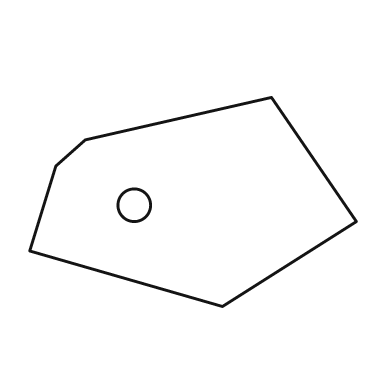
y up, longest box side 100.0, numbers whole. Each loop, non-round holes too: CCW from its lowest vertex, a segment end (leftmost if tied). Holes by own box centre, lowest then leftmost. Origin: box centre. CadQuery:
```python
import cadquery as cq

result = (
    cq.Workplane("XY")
    .moveTo(9.0, -32.0)
    .lineTo(50.0, -6.0)
    .lineTo(24.0, 32.0)
    .lineTo(-33.0, 19.0)
    .lineTo(-42.0, 11.0)
    .lineTo(-50.0, -15.0)
    .close()
    .moveTo(-18.0, -1.0)
    .circle(5.0)
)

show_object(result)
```